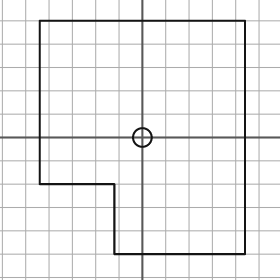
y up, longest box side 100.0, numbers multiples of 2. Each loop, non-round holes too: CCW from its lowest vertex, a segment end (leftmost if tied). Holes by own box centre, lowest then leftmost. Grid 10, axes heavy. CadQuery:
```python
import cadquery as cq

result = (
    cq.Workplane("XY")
    .moveTo(-12.0, -50.0)
    .lineTo(44.0, -50.0)
    .lineTo(44.0, 50.0)
    .lineTo(-44.0, 50.0)
    .lineTo(-44.0, -20.0)
    .lineTo(-12.0, -20.0)
    .close()
    .moveTo(0.0, 0.0)
    .circle(4.0)
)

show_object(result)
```